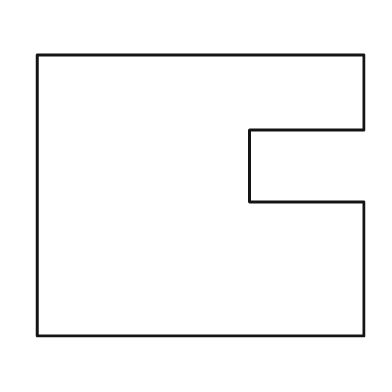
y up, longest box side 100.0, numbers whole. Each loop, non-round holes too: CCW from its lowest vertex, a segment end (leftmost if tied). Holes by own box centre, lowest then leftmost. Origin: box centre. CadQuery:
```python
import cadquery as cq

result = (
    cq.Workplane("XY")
    .moveTo(-50.0, -43.0)
    .lineTo(50.0, -43.0)
    .lineTo(50.0, -2.0)
    .lineTo(15.0, -2.0)
    .lineTo(15.0, 20.0)
    .lineTo(50.0, 20.0)
    .lineTo(50.0, 43.0)
    .lineTo(-50.0, 43.0)
    .close()
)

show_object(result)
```